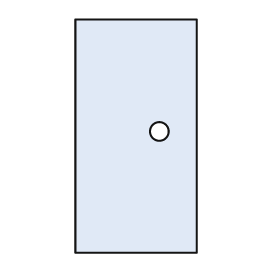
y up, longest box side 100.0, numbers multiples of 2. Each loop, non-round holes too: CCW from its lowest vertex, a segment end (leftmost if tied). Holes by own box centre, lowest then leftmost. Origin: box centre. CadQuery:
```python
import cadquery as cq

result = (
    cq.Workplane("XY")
    .moveTo(-26.0, -50.0)
    .lineTo(26.0, -50.0)
    .lineTo(26.0, 50.0)
    .lineTo(-26.0, 50.0)
    .close()
    .moveTo(10.0, 2.0)
    .circle(4.0)
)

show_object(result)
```